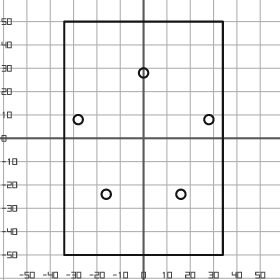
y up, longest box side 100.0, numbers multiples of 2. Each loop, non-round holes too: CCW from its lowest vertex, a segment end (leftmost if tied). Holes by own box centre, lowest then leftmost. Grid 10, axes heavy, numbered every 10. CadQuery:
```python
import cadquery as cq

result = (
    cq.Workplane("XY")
    .moveTo(-34.0, -50.0)
    .lineTo(34.0, -50.0)
    .lineTo(34.0, 50.0)
    .lineTo(-34.0, 50.0)
    .close()
    .moveTo(-16.0, -24.0)
    .circle(2.0)
    .moveTo(16.0, -24.0)
    .circle(2.0)
    .moveTo(-28.0, 8.0)
    .circle(2.0)
    .moveTo(28.0, 8.0)
    .circle(2.0)
    .moveTo(0.0, 28.0)
    .circle(2.0)
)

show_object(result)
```